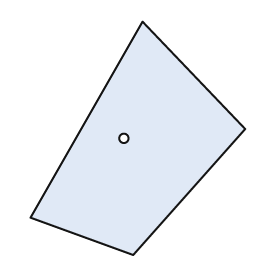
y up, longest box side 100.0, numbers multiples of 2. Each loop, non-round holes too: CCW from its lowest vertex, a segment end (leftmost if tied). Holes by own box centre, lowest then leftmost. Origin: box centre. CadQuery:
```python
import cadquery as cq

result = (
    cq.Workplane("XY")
    .moveTo(-2.0, -50.0)
    .lineTo(46.0, 4.0)
    .lineTo(2.0, 50.0)
    .lineTo(-46.0, -34.0)
    .close()
    .moveTo(-6.0, 0.0)
    .circle(2.0)
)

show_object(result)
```